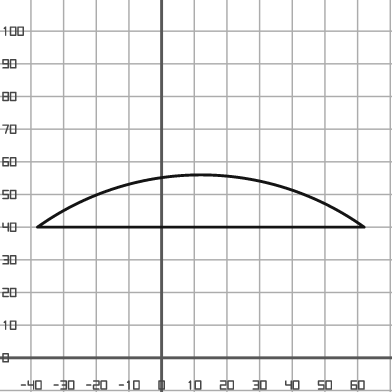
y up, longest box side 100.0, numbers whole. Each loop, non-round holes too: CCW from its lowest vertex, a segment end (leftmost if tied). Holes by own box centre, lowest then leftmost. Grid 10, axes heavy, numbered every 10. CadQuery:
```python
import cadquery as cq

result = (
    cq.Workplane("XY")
    .moveTo(-38.0, 40.0)
    .lineTo(62.0, 40.0)
    .threePointArc((12.0, 56.0), (-38.0, 40.0))
    .close()
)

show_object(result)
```